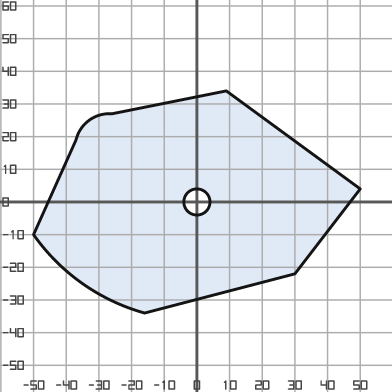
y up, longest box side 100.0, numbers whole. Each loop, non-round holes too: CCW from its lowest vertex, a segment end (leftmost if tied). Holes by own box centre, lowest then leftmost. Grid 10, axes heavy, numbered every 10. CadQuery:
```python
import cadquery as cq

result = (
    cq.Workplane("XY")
    .moveTo(-16.0, -34.0)
    .lineTo(30.0, -22.0)
    .lineTo(50.0, 4.0)
    .lineTo(9.0, 34.0)
    .lineTo(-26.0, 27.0)
    .threePointArc((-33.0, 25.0), (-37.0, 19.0))
    .lineTo(-50.0, -10.0)
    .threePointArc((-35.0, -25.0), (-16.0, -34.0))
    .close()
    .moveTo(0.0, 0.0)
    .circle(4.0)
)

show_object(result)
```